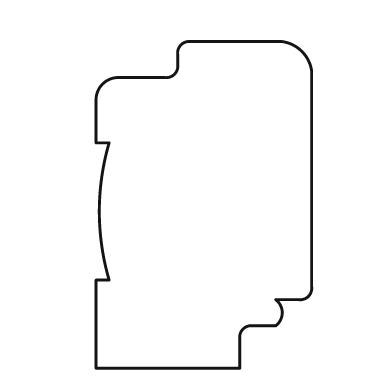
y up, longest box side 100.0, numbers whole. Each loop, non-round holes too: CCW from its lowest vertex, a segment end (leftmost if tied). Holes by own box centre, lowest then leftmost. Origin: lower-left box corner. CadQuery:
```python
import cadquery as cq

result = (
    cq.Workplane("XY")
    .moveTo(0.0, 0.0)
    .lineTo(44.0, 0.0)
    .lineTo(44.0, 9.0)
    .threePointArc((45.0, 12.0), (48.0, 13.0))
    .lineTo(55.0, 13.0)
    .threePointArc((57.0, 17.0), (55.0, 21.0))
    .lineTo(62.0, 21.0)
    .threePointArc((65.0, 22.0), (66.0, 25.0))
    .lineTo(66.0, 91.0)
    .threePointArc((63.0, 97.0), (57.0, 100.0))
    .lineTo(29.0, 100.0)
    .threePointArc((26.0, 99.0), (25.0, 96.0))
    .lineTo(25.0, 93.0)
    .threePointArc((24.0, 90.0), (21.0, 89.0))
    .lineTo(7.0, 89.0)
    .threePointArc((2.0, 87.0), (0.0, 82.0))
    .lineTo(0.0, 69.0)
    .lineTo(4.0, 69.0)
    .threePointArc((1.0, 48.0), (4.0, 27.0))
    .lineTo(0.0, 27.0)
    .close()
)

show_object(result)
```